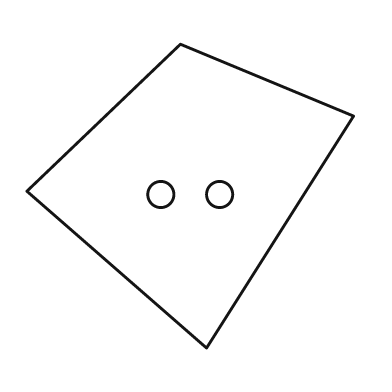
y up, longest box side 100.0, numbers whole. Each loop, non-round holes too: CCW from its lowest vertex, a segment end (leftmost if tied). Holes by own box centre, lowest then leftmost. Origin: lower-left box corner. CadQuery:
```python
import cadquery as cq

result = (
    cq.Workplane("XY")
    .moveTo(55.0, 0.0)
    .lineTo(100.0, 71.0)
    .lineTo(47.0, 93.0)
    .lineTo(0.0, 48.0)
    .close()
    .moveTo(41.0, 47.0)
    .circle(4.0)
    .moveTo(59.0, 47.0)
    .circle(4.0)
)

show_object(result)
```